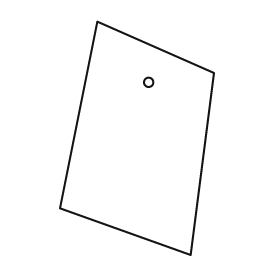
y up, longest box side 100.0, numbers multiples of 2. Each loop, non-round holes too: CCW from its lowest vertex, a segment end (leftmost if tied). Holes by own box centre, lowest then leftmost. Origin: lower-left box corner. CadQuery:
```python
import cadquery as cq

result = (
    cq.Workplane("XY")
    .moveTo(56.0, 0.0)
    .lineTo(66.0, 78.0)
    .lineTo(16.0, 100.0)
    .lineTo(0.0, 20.0)
    .close()
    .moveTo(38.0, 74.0)
    .circle(2.0)
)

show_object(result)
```